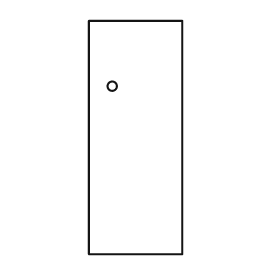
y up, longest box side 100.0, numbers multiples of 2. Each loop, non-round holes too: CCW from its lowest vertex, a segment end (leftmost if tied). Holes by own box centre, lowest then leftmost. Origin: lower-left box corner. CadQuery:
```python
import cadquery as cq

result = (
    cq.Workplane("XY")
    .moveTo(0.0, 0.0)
    .lineTo(40.0, 0.0)
    .lineTo(40.0, 100.0)
    .lineTo(0.0, 100.0)
    .close()
    .moveTo(10.0, 72.0)
    .circle(2.0)
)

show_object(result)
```